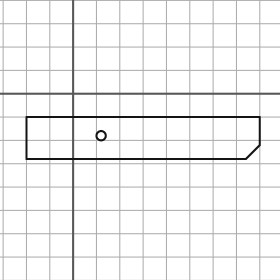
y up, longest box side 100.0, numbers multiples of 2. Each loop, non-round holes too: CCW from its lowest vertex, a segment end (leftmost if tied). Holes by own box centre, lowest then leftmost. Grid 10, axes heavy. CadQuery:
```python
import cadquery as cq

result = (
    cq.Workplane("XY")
    .moveTo(-20.0, -28.0)
    .lineTo(74.0, -28.0)
    .lineTo(80.0, -22.0)
    .lineTo(80.0, -10.0)
    .lineTo(-20.0, -10.0)
    .close()
    .moveTo(12.0, -18.0)
    .circle(2.0)
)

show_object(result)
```